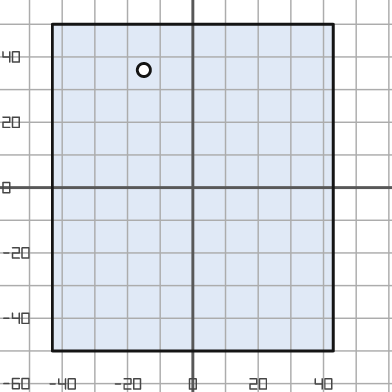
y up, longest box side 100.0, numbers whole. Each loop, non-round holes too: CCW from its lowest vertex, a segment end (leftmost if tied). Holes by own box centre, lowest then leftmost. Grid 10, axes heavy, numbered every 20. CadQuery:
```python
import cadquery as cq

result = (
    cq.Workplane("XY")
    .moveTo(-43.0, -50.0)
    .lineTo(43.0, -50.0)
    .lineTo(43.0, 50.0)
    .lineTo(-43.0, 50.0)
    .close()
    .moveTo(-15.0, 36.0)
    .circle(2.0)
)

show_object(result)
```